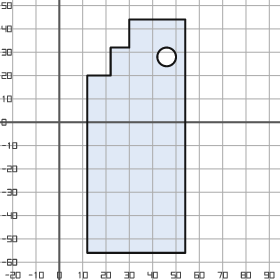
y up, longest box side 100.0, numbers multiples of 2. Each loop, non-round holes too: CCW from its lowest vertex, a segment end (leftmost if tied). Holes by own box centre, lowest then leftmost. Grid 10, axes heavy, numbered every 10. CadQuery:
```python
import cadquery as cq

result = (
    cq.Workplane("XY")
    .moveTo(12.0, -56.0)
    .lineTo(54.0, -56.0)
    .lineTo(54.0, 44.0)
    .lineTo(30.0, 44.0)
    .lineTo(30.0, 32.0)
    .lineTo(22.0, 32.0)
    .lineTo(22.0, 20.0)
    .lineTo(12.0, 20.0)
    .close()
    .moveTo(46.0, 28.0)
    .circle(4.0)
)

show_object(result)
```